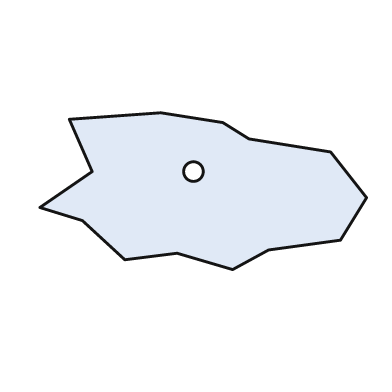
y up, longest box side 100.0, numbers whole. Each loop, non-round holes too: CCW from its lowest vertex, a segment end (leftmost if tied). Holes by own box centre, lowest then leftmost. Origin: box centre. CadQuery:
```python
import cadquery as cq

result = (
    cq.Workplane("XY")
    .moveTo(9.0, -24.0)
    .lineTo(20.0, -18.0)
    .lineTo(42.0, -15.0)
    .lineTo(50.0, -2.0)
    .lineTo(39.0, 12.0)
    .lineTo(14.0, 16.0)
    .lineTo(6.0, 21.0)
    .lineTo(-13.0, 24.0)
    .lineTo(-41.0, 22.0)
    .lineTo(-34.0, 6.0)
    .lineTo(-50.0, -5.0)
    .lineTo(-37.0, -9.0)
    .lineTo(-24.0, -21.0)
    .lineTo(-8.0, -19.0)
    .close()
    .moveTo(-3.0, 6.0)
    .circle(3.0)
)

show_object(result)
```